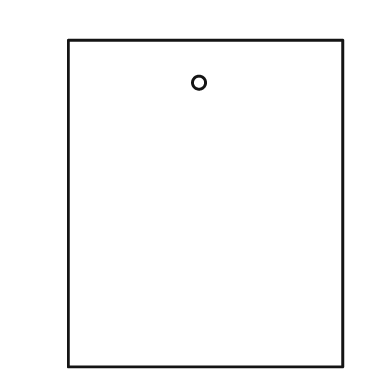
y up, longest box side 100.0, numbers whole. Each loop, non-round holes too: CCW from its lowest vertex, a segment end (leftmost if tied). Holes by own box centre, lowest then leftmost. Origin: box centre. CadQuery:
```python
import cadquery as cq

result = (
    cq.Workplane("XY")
    .moveTo(-42.0, -50.0)
    .lineTo(42.0, -50.0)
    .lineTo(42.0, 50.0)
    .lineTo(-42.0, 50.0)
    .close()
    .moveTo(-2.0, 37.0)
    .circle(2.0)
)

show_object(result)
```